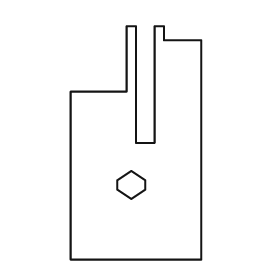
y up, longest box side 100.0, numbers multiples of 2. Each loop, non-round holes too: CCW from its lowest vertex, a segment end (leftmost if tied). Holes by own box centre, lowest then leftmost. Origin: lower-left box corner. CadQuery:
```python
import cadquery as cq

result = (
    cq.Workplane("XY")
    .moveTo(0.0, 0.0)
    .lineTo(56.0, 0.0)
    .lineTo(56.0, 94.0)
    .lineTo(40.0, 94.0)
    .lineTo(40.0, 100.0)
    .lineTo(36.0, 100.0)
    .lineTo(36.0, 50.0)
    .lineTo(28.0, 50.0)
    .lineTo(28.0, 100.0)
    .lineTo(24.0, 100.0)
    .lineTo(24.0, 72.0)
    .lineTo(0.0, 72.0)
    .close()
    .moveTo(26.0, 26.0)
    .lineTo(32.0, 30.0)
    .lineTo(32.0, 34.0)
    .lineTo(26.0, 38.0)
    .lineTo(20.0, 34.0)
    .lineTo(20.0, 30.0)
    .close()
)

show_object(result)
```